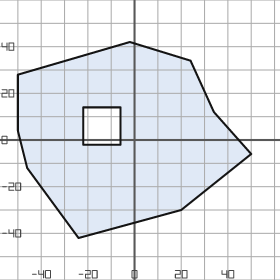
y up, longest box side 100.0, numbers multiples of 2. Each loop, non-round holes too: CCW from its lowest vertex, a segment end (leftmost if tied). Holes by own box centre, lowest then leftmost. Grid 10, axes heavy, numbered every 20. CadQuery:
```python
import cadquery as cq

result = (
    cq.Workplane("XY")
    .moveTo(-24.0, -42.0)
    .lineTo(20.0, -30.0)
    .lineTo(50.0, -6.0)
    .lineTo(34.0, 12.0)
    .lineTo(24.0, 34.0)
    .lineTo(-2.0, 42.0)
    .lineTo(-50.0, 28.0)
    .lineTo(-50.0, 4.0)
    .lineTo(-46.0, -12.0)
    .close()
    .moveTo(-22.0, -2.0)
    .lineTo(-6.0, -2.0)
    .lineTo(-6.0, 14.0)
    .lineTo(-22.0, 14.0)
    .close()
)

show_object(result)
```